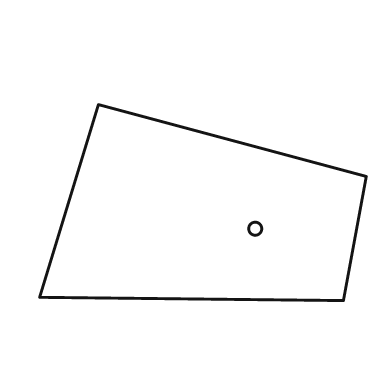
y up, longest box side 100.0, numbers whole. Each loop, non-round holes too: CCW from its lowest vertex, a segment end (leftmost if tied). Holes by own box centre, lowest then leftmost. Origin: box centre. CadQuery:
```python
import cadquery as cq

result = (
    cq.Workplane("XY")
    .moveTo(43.0, -30.0)
    .lineTo(50.0, 8.0)
    .lineTo(-32.0, 30.0)
    .lineTo(-50.0, -29.0)
    .close()
    .moveTo(16.0, -8.0)
    .circle(2.0)
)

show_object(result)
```